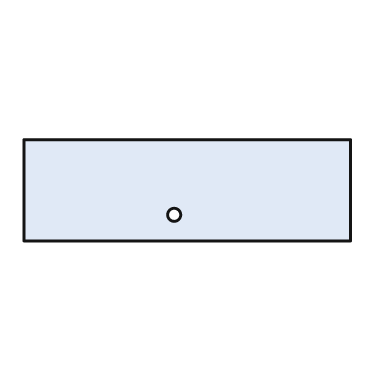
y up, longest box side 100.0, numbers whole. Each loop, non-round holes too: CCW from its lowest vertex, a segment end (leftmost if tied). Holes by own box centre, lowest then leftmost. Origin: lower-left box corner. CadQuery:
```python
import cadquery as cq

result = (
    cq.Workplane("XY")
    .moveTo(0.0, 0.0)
    .lineTo(100.0, 0.0)
    .lineTo(100.0, 31.0)
    .lineTo(0.0, 31.0)
    .close()
    .moveTo(46.0, 8.0)
    .circle(2.0)
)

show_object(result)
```